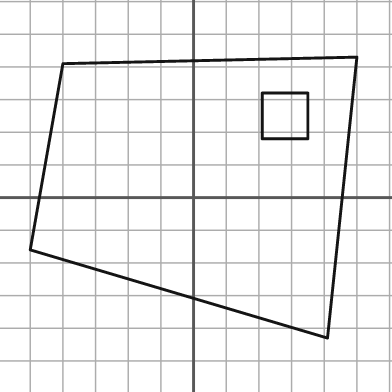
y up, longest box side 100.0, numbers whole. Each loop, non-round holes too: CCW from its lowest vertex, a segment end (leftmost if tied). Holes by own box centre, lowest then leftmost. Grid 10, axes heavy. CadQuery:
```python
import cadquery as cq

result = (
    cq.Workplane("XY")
    .moveTo(41.0, -43.0)
    .lineTo(50.0, 43.0)
    .lineTo(-40.0, 41.0)
    .lineTo(-50.0, -16.0)
    .close()
    .moveTo(21.0, 18.0)
    .lineTo(35.0, 18.0)
    .lineTo(35.0, 32.0)
    .lineTo(21.0, 32.0)
    .close()
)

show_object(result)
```